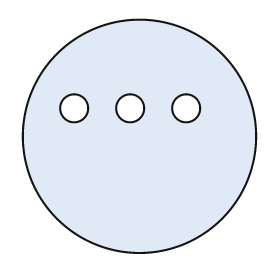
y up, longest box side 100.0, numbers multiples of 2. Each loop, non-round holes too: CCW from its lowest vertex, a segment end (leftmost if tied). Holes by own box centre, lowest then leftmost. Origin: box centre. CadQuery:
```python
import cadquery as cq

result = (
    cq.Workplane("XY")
    .moveTo(0.0, 0.0)
    .circle(50.0)
    .moveTo(-28.0, 12.0)
    .circle(6.0)
    .moveTo(-4.0, 12.0)
    .circle(6.0)
    .moveTo(20.0, 12.0)
    .circle(6.0)
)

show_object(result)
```